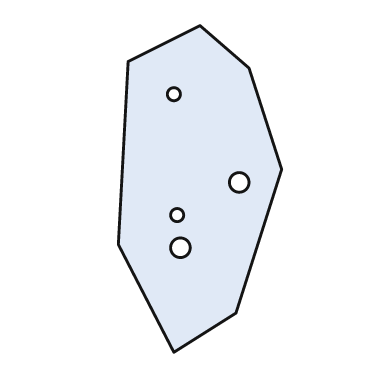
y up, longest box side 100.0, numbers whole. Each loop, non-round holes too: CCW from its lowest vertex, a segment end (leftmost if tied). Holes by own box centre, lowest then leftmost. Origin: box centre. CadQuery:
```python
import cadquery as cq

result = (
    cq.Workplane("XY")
    .moveTo(-8.0, -50.0)
    .lineTo(11.0, -38.0)
    .lineTo(25.0, 6.0)
    .lineTo(15.0, 37.0)
    .lineTo(0.0, 50.0)
    .lineTo(-22.0, 39.0)
    .lineTo(-25.0, -17.0)
    .close()
    .moveTo(-6.0, -18.0)
    .circle(3.0)
    .moveTo(-7.0, -8.0)
    .circle(2.0)
    .moveTo(12.0, 2.0)
    .circle(3.0)
    .moveTo(-8.0, 29.0)
    .circle(2.0)
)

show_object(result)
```